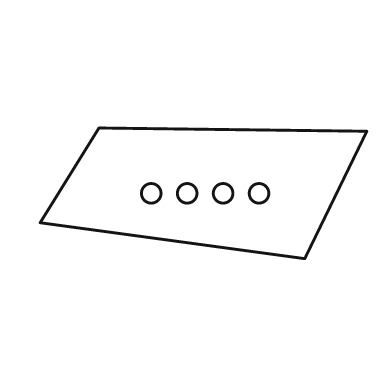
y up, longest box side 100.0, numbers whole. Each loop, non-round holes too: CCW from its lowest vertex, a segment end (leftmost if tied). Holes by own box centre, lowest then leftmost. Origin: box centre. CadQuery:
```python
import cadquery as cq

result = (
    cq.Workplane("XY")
    .moveTo(31.0, -20.0)
    .lineTo(50.0, 19.0)
    .lineTo(-32.0, 20.0)
    .lineTo(-50.0, -9.0)
    .close()
    .moveTo(-16.0, 0.0)
    .circle(3.0)
    .moveTo(-5.0, 0.0)
    .circle(3.0)
    .moveTo(6.0, 0.0)
    .circle(3.0)
    .moveTo(17.0, 0.0)
    .circle(3.0)
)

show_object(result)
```